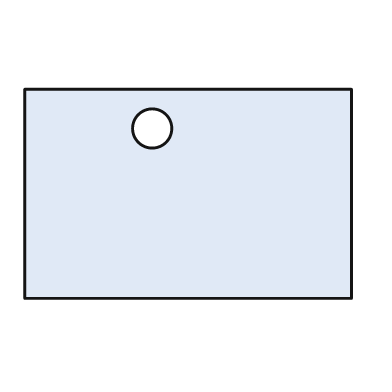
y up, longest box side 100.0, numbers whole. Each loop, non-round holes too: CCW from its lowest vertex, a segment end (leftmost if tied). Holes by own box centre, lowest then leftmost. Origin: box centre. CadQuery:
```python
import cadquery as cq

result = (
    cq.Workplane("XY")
    .moveTo(-50.0, -32.0)
    .lineTo(50.0, -32.0)
    .lineTo(50.0, 32.0)
    .lineTo(-50.0, 32.0)
    .close()
    .moveTo(-11.0, 20.0)
    .circle(6.0)
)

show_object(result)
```